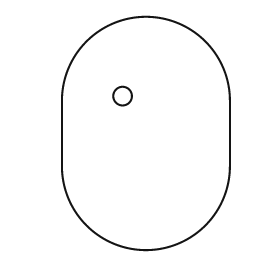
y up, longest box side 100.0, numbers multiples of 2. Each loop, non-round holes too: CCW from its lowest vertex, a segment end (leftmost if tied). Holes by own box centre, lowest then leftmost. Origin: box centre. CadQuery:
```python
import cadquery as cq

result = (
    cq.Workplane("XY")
    .moveTo(-36.0, -14.0)
    .threePointArc((0.0, -50.0), (36.0, -14.0))
    .lineTo(36.0, 14.0)
    .threePointArc((0.0, 50.0), (-36.0, 14.0))
    .close()
    .moveTo(-10.0, 16.0)
    .circle(4.0)
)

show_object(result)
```